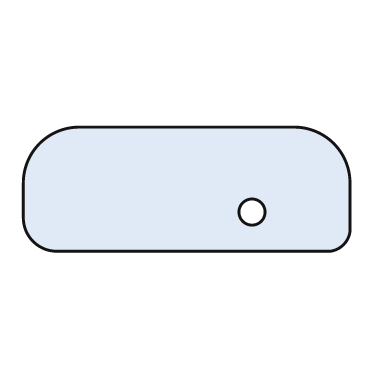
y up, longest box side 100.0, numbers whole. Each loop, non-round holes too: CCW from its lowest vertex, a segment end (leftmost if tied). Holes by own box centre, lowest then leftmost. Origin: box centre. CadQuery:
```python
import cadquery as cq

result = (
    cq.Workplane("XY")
    .moveTo(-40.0, -19.0)
    .lineTo(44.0, -19.0)
    .threePointArc((48.0, -17.0), (50.0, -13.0))
    .lineTo(50.0, 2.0)
    .threePointArc((45.0, 14.0), (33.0, 19.0))
    .lineTo(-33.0, 19.0)
    .threePointArc((-45.0, 14.0), (-50.0, 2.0))
    .lineTo(-50.0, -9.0)
    .threePointArc((-47.0, -16.0), (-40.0, -19.0))
    .close()
    .moveTo(20.0, -7.0)
    .circle(4.0)
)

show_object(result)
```